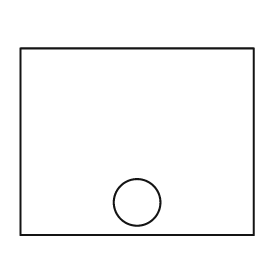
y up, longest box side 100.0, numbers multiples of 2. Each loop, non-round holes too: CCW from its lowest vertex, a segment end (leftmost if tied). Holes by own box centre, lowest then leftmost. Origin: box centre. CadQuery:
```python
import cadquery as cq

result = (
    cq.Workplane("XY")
    .moveTo(-50.0, -40.0)
    .lineTo(50.0, -40.0)
    .lineTo(50.0, 40.0)
    .lineTo(-50.0, 40.0)
    .close()
    .moveTo(0.0, -26.0)
    .circle(10.0)
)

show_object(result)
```